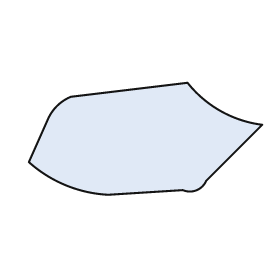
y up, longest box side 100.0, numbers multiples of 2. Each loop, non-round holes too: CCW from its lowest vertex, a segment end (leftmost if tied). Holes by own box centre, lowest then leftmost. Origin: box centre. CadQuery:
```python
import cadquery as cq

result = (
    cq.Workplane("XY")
    .moveTo(-16.0, -24.0)
    .lineTo(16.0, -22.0)
    .threePointArc((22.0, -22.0), (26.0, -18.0))
    .lineTo(50.0, 6.0)
    .threePointArc((32.0, 12.0), (18.0, 24.0))
    .lineTo(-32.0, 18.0)
    .threePointArc((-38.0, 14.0), (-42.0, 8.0))
    .lineTo(-50.0, -10.0)
    .threePointArc((-34.0, -20.0), (-16.0, -24.0))
    .close()
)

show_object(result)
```